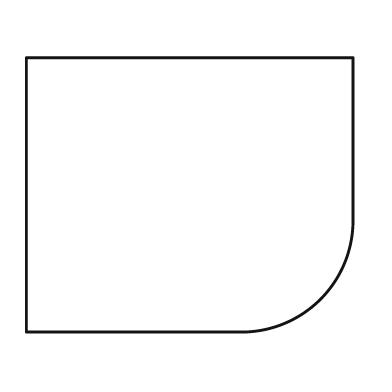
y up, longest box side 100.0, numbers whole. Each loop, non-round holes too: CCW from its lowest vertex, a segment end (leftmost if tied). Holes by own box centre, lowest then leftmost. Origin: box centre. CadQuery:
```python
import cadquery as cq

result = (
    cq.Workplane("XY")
    .moveTo(-50.0, -42.0)
    .lineTo(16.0, -42.0)
    .threePointArc((40.0, -32.0), (50.0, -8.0))
    .lineTo(50.0, 42.0)
    .lineTo(-50.0, 42.0)
    .close()
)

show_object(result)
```